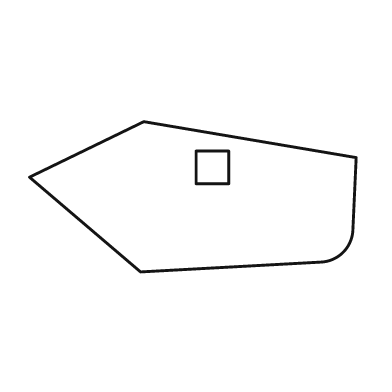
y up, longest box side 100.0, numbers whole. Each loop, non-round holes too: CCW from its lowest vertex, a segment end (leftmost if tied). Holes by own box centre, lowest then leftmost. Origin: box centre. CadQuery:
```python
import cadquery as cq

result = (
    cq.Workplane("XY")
    .moveTo(-16.0, -23.0)
    .lineTo(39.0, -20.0)
    .threePointArc((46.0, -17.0), (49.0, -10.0))
    .lineTo(50.0, 12.0)
    .lineTo(-15.0, 23.0)
    .lineTo(-50.0, 6.0)
    .close()
    .moveTo(1.0, 4.0)
    .lineTo(11.0, 4.0)
    .lineTo(11.0, 14.0)
    .lineTo(1.0, 14.0)
    .close()
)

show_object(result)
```